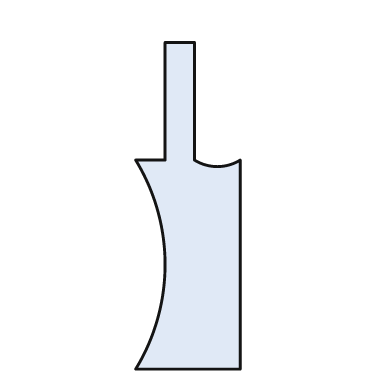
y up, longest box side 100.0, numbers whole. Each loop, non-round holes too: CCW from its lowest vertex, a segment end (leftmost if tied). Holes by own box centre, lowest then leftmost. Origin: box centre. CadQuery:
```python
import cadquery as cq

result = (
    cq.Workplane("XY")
    .moveTo(-16.0, -50.0)
    .lineTo(16.0, -50.0)
    .lineTo(16.0, 14.0)
    .threePointArc((9.0, 12.0), (2.0, 14.0))
    .lineTo(2.0, 50.0)
    .lineTo(-7.0, 50.0)
    .lineTo(-7.0, 14.0)
    .lineTo(-16.0, 14.0)
    .threePointArc((-7.0, -18.0), (-16.0, -50.0))
    .close()
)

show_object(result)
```